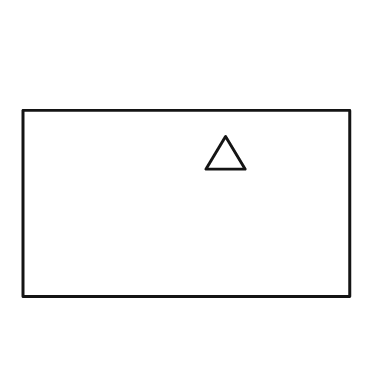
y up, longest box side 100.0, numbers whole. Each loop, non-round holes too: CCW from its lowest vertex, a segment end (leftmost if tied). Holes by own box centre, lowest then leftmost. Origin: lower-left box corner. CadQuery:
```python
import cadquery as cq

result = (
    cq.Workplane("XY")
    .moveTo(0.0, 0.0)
    .lineTo(100.0, 0.0)
    .lineTo(100.0, 57.0)
    .lineTo(0.0, 57.0)
    .close()
    .moveTo(56.0, 39.0)
    .lineTo(68.0, 39.0)
    .lineTo(62.0, 49.0)
    .close()
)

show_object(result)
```